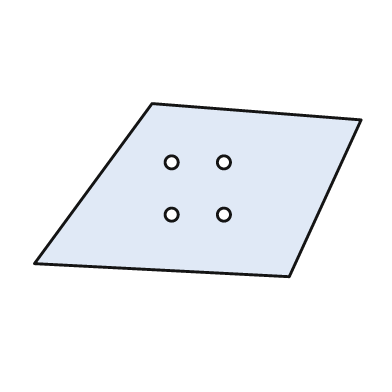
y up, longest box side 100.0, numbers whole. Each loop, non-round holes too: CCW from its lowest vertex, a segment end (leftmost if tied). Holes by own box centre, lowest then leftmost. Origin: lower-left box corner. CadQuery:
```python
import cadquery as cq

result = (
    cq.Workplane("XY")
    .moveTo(78.0, 0.0)
    .lineTo(100.0, 48.0)
    .lineTo(36.0, 53.0)
    .lineTo(0.0, 4.0)
    .close()
    .moveTo(42.0, 19.0)
    .circle(2.0)
    .moveTo(58.0, 19.0)
    .circle(2.0)
    .moveTo(42.0, 35.0)
    .circle(2.0)
    .moveTo(58.0, 35.0)
    .circle(2.0)
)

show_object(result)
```